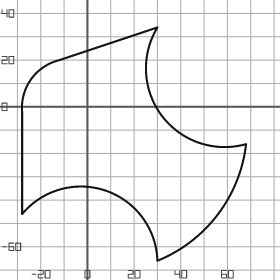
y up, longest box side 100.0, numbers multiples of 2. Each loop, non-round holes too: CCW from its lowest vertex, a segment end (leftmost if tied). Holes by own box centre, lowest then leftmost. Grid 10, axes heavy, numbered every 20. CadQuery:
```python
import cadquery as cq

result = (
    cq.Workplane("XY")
    .moveTo(30.0, -66.0)
    .threePointArc((56.0, -46.0), (68.0, -16.0))
    .threePointArc((32.0, -4.0), (30.0, 34.0))
    .lineTo(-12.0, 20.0)
    .threePointArc((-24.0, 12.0), (-28.0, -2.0))
    .lineTo(-28.0, -46.0)
    .threePointArc((8.0, -36.0), (30.0, -66.0))
    .close()
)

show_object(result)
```